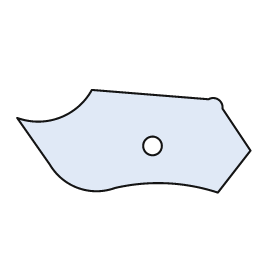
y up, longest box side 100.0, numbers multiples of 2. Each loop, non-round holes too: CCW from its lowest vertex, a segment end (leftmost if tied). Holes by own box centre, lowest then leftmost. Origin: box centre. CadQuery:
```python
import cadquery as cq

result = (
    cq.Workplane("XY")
    .moveTo(36.0, -22.0)
    .lineTo(50.0, -4.0)
    .lineTo(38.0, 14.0)
    .threePointArc((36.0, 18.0), (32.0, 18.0))
    .lineTo(-18.0, 22.0)
    .threePointArc((-32.0, 10.0), (-50.0, 10.0))
    .lineTo(-36.0, -10.0)
    .threePointArc((-24.0, -20.0), (-8.0, -20.0))
    .threePointArc((14.0, -18.0), (36.0, -22.0))
    .close()
    .moveTo(8.0, -2.0)
    .circle(4.0)
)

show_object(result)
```